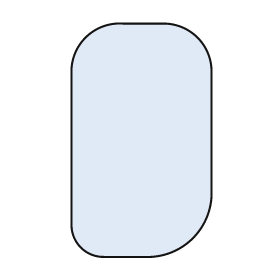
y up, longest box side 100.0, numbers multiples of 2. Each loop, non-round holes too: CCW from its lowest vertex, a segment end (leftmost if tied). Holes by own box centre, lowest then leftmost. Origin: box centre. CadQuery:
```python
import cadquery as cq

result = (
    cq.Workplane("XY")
    .moveTo(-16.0, -50.0)
    .lineTo(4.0, -50.0)
    .threePointArc((22.0, -42.0), (30.0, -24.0))
    .lineTo(30.0, 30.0)
    .threePointArc((24.0, 44.0), (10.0, 50.0))
    .lineTo(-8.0, 50.0)
    .threePointArc((-24.0, 44.0), (-30.0, 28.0))
    .lineTo(-30.0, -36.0)
    .threePointArc((-26.0, -46.0), (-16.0, -50.0))
    .close()
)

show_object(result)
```